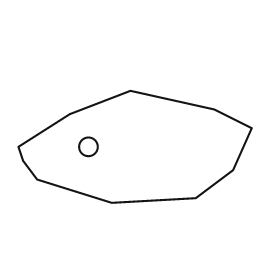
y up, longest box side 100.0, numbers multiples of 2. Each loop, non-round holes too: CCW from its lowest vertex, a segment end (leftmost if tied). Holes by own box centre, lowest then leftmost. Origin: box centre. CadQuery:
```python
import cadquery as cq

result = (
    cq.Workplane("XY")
    .moveTo(-10.0, -24.0)
    .lineTo(26.0, -22.0)
    .lineTo(42.0, -10.0)
    .lineTo(50.0, 8.0)
    .lineTo(34.0, 16.0)
    .lineTo(-2.0, 24.0)
    .lineTo(-28.0, 14.0)
    .lineTo(-50.0, 0.0)
    .lineTo(-48.0, -6.0)
    .lineTo(-42.0, -14.0)
    .close()
    .moveTo(-20.0, 0.0)
    .circle(4.0)
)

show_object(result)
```